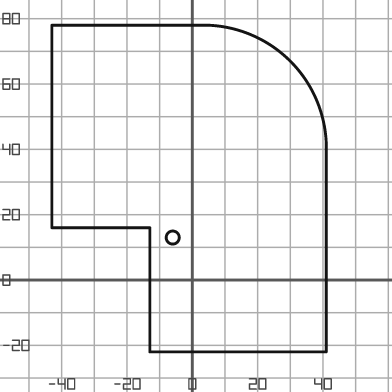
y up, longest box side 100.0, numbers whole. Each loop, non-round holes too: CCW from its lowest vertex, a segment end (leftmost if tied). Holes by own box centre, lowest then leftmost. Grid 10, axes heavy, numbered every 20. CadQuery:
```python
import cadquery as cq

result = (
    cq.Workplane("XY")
    .moveTo(-13.0, -22.0)
    .lineTo(41.0, -22.0)
    .lineTo(41.0, 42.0)
    .threePointArc((30.0, 67.0), (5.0, 78.0))
    .lineTo(-43.0, 78.0)
    .lineTo(-43.0, 16.0)
    .lineTo(-13.0, 16.0)
    .close()
    .moveTo(-6.0, 13.0)
    .circle(2.0)
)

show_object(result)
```